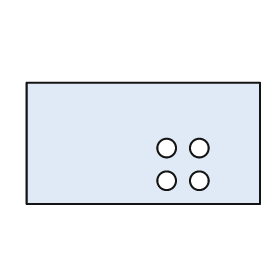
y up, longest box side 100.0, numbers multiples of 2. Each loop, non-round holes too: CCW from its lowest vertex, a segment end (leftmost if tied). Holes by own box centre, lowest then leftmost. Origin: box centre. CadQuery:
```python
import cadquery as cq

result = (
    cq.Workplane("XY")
    .moveTo(-50.0, -26.0)
    .lineTo(50.0, -26.0)
    .lineTo(50.0, 26.0)
    .lineTo(-50.0, 26.0)
    .close()
    .moveTo(10.0, -16.0)
    .circle(4.0)
    .moveTo(24.0, -16.0)
    .circle(4.0)
    .moveTo(10.0, -2.0)
    .circle(4.0)
    .moveTo(24.0, -2.0)
    .circle(4.0)
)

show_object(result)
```